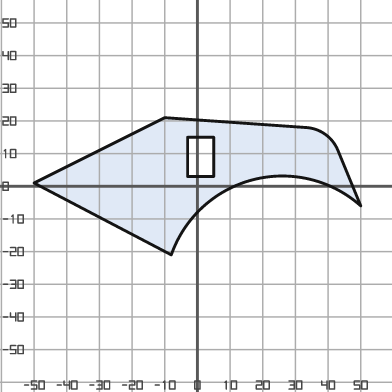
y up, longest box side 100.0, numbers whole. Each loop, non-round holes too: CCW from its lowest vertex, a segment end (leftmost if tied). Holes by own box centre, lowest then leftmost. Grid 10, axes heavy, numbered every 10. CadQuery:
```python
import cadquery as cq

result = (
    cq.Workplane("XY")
    .moveTo(-8.0, -21.0)
    .threePointArc((17.0, 2.0), (50.0, -6.0))
    .lineTo(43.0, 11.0)
    .threePointArc((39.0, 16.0), (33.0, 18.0))
    .lineTo(-10.0, 21.0)
    .lineTo(-50.0, 1.0)
    .close()
    .moveTo(-3.0, 3.0)
    .lineTo(5.0, 3.0)
    .lineTo(5.0, 15.0)
    .lineTo(-3.0, 15.0)
    .close()
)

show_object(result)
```